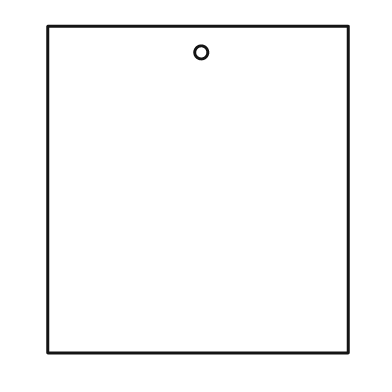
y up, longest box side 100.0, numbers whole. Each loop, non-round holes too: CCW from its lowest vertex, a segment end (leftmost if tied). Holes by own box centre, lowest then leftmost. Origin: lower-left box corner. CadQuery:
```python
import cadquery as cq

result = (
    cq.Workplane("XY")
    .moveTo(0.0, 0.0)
    .lineTo(92.0, 0.0)
    .lineTo(92.0, 100.0)
    .lineTo(0.0, 100.0)
    .close()
    .moveTo(47.0, 92.0)
    .circle(2.0)
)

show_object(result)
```